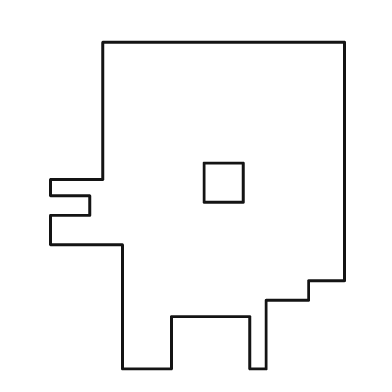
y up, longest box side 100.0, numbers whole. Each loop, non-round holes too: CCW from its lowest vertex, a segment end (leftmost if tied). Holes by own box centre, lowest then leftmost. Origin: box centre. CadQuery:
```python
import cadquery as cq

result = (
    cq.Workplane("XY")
    .moveTo(-23.0, -50.0)
    .lineTo(-8.0, -50.0)
    .lineTo(-8.0, -34.0)
    .lineTo(16.0, -34.0)
    .lineTo(16.0, -50.0)
    .lineTo(21.0, -50.0)
    .lineTo(21.0, -29.0)
    .lineTo(34.0, -29.0)
    .lineTo(34.0, -23.0)
    .lineTo(45.0, -23.0)
    .lineTo(45.0, 50.0)
    .lineTo(-29.0, 50.0)
    .lineTo(-29.0, 8.0)
    .lineTo(-45.0, 8.0)
    .lineTo(-45.0, 3.0)
    .lineTo(-33.0, 3.0)
    .lineTo(-33.0, -3.0)
    .lineTo(-45.0, -3.0)
    .lineTo(-45.0, -12.0)
    .lineTo(-23.0, -12.0)
    .close()
    .moveTo(2.0, 1.0)
    .lineTo(14.0, 1.0)
    .lineTo(14.0, 13.0)
    .lineTo(2.0, 13.0)
    .close()
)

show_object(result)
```